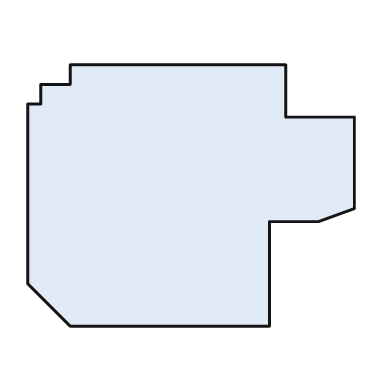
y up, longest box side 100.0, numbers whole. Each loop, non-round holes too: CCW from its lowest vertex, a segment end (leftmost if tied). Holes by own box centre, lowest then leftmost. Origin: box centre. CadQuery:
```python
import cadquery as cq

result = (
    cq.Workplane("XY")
    .moveTo(-37.0, -40.0)
    .lineTo(24.0, -40.0)
    .lineTo(24.0, -8.0)
    .lineTo(39.0, -8.0)
    .lineTo(50.0, -4.0)
    .lineTo(50.0, 24.0)
    .lineTo(29.0, 24.0)
    .lineTo(29.0, 40.0)
    .lineTo(-37.0, 40.0)
    .lineTo(-37.0, 34.0)
    .lineTo(-46.0, 34.0)
    .lineTo(-46.0, 28.0)
    .lineTo(-50.0, 28.0)
    .lineTo(-50.0, -27.0)
    .close()
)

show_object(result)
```